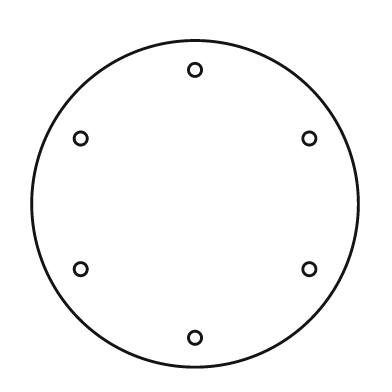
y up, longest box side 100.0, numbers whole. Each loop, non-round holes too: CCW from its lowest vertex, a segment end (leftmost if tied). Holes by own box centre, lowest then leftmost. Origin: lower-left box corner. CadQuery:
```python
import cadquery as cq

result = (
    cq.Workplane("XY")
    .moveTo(50.0, 50.0)
    .circle(50.0)
    .moveTo(50.0, 9.0)
    .circle(2.0)
    .moveTo(15.0, 30.0)
    .circle(2.0)
    .moveTo(85.0, 30.0)
    .circle(2.0)
    .moveTo(15.0, 70.0)
    .circle(2.0)
    .moveTo(85.0, 70.0)
    .circle(2.0)
    .moveTo(50.0, 91.0)
    .circle(2.0)
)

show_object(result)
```